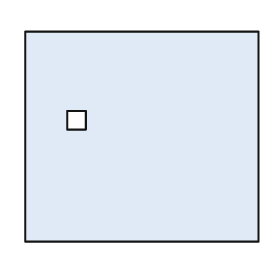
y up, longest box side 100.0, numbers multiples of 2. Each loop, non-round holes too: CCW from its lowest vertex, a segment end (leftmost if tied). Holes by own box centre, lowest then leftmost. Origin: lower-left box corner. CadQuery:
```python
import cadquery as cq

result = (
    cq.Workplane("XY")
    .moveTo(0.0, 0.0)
    .lineTo(100.0, 0.0)
    .lineTo(100.0, 90.0)
    .lineTo(0.0, 90.0)
    .close()
    .moveTo(18.0, 48.0)
    .lineTo(26.0, 48.0)
    .lineTo(26.0, 56.0)
    .lineTo(18.0, 56.0)
    .close()
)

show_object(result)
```